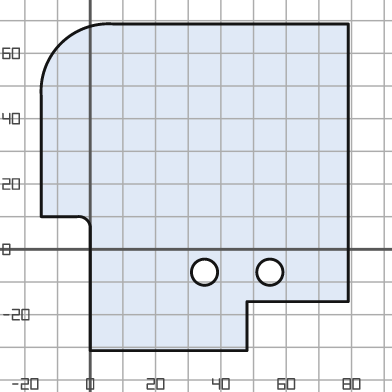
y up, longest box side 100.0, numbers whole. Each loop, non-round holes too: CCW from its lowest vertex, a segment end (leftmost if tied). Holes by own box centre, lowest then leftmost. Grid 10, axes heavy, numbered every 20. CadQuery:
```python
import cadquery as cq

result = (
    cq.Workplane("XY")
    .moveTo(0.0, -31.0)
    .lineTo(48.0, -31.0)
    .lineTo(48.0, -16.0)
    .lineTo(79.0, -16.0)
    .lineTo(79.0, 69.0)
    .lineTo(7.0, 69.0)
    .threePointArc((-9.0, 63.0), (-15.0, 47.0))
    .lineTo(-15.0, 10.0)
    .lineTo(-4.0, 10.0)
    .threePointArc((-1.0, 9.0), (0.0, 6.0))
    .close()
    .moveTo(35.0, -7.0)
    .circle(4.0)
    .moveTo(55.0, -7.0)
    .circle(4.0)
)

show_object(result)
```